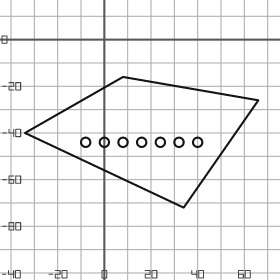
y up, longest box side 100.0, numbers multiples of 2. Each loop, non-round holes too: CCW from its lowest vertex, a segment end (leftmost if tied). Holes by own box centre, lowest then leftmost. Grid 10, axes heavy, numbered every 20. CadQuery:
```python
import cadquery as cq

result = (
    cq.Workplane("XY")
    .moveTo(34.0, -72.0)
    .lineTo(66.0, -26.0)
    .lineTo(8.0, -16.0)
    .lineTo(-34.0, -40.0)
    .close()
    .moveTo(-8.0, -44.0)
    .circle(2.0)
    .moveTo(0.0, -44.0)
    .circle(2.0)
    .moveTo(8.0, -44.0)
    .circle(2.0)
    .moveTo(16.0, -44.0)
    .circle(2.0)
    .moveTo(24.0, -44.0)
    .circle(2.0)
    .moveTo(32.0, -44.0)
    .circle(2.0)
    .moveTo(40.0, -44.0)
    .circle(2.0)
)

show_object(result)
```